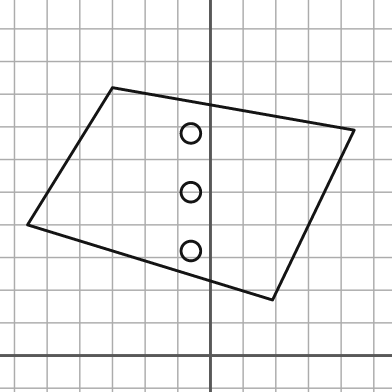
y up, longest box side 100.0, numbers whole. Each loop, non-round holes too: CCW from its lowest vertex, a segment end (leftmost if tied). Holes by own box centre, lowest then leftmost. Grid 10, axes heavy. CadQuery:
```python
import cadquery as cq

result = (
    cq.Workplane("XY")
    .moveTo(19.0, 17.0)
    .lineTo(44.0, 69.0)
    .lineTo(-30.0, 82.0)
    .lineTo(-56.0, 40.0)
    .close()
    .moveTo(-6.0, 32.0)
    .circle(3.0)
    .moveTo(-6.0, 50.0)
    .circle(3.0)
    .moveTo(-6.0, 68.0)
    .circle(3.0)
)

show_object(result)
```